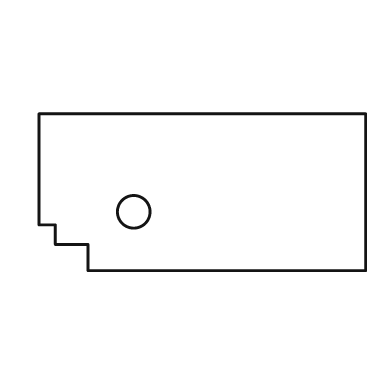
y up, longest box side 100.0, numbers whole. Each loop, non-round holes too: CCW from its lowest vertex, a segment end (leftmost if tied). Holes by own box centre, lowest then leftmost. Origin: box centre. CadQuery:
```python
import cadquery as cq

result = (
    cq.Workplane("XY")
    .moveTo(-35.0, -24.0)
    .lineTo(50.0, -24.0)
    .lineTo(50.0, 24.0)
    .lineTo(-50.0, 24.0)
    .lineTo(-50.0, -10.0)
    .lineTo(-45.0, -10.0)
    .lineTo(-45.0, -16.0)
    .lineTo(-35.0, -16.0)
    .close()
    .moveTo(-21.0, -6.0)
    .circle(5.0)
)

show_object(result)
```